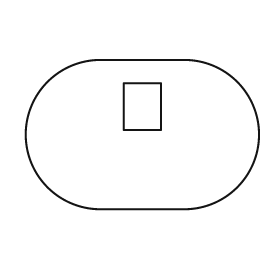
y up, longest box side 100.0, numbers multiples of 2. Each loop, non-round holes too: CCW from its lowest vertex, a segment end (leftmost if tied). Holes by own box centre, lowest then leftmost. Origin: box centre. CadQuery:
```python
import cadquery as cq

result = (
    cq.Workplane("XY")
    .moveTo(-18.0, -32.0)
    .lineTo(18.0, -32.0)
    .threePointArc((50.0, 0.0), (18.0, 32.0))
    .lineTo(-18.0, 32.0)
    .threePointArc((-50.0, 0.0), (-18.0, -32.0))
    .close()
    .moveTo(-8.0, 2.0)
    .lineTo(8.0, 2.0)
    .lineTo(8.0, 22.0)
    .lineTo(-8.0, 22.0)
    .close()
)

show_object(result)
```